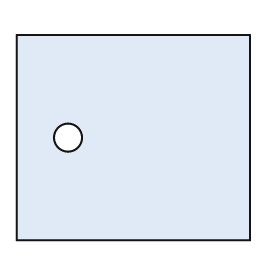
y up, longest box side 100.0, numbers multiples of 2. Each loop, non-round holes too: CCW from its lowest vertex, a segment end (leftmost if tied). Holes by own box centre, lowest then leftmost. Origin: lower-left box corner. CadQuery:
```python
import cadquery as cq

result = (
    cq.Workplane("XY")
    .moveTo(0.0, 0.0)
    .lineTo(100.0, 0.0)
    .lineTo(100.0, 88.0)
    .lineTo(0.0, 88.0)
    .close()
    .moveTo(22.0, 44.0)
    .circle(6.0)
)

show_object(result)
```